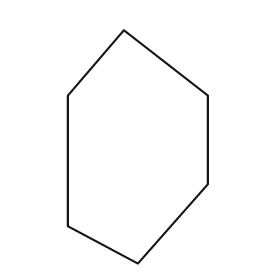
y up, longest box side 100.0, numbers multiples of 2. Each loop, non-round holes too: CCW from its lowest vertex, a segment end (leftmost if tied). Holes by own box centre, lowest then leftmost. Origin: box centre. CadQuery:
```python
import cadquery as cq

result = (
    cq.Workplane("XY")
    .moveTo(0.0, -50.0)
    .lineTo(30.0, -16.0)
    .lineTo(30.0, 22.0)
    .lineTo(-6.0, 50.0)
    .lineTo(-30.0, 22.0)
    .lineTo(-30.0, -34.0)
    .close()
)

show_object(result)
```